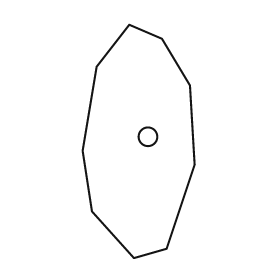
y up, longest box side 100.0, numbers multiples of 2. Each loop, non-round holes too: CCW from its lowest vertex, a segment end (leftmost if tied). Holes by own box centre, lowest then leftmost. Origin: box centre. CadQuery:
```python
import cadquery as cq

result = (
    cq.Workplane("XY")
    .moveTo(-2.0, -50.0)
    .lineTo(12.0, -46.0)
    .lineTo(24.0, -10.0)
    .lineTo(22.0, 24.0)
    .lineTo(10.0, 44.0)
    .lineTo(-4.0, 50.0)
    .lineTo(-18.0, 32.0)
    .lineTo(-24.0, -4.0)
    .lineTo(-20.0, -30.0)
    .close()
    .moveTo(4.0, 2.0)
    .circle(4.0)
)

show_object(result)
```